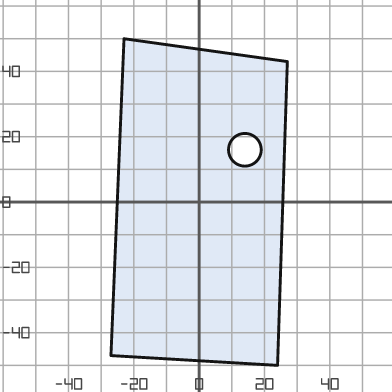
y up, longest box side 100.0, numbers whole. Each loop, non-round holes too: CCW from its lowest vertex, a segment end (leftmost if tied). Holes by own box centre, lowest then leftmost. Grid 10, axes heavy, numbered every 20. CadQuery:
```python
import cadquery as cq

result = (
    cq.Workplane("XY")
    .moveTo(24.0, -50.0)
    .lineTo(27.0, 43.0)
    .lineTo(-23.0, 50.0)
    .lineTo(-27.0, -47.0)
    .close()
    .moveTo(14.0, 16.0)
    .circle(5.0)
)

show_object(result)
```